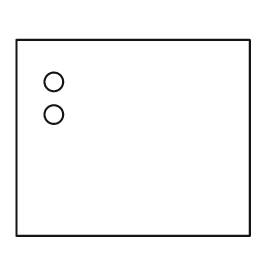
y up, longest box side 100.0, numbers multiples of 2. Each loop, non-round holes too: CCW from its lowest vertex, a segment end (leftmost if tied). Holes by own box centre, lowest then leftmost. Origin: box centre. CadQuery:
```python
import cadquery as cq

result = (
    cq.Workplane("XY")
    .moveTo(-50.0, -42.0)
    .lineTo(50.0, -42.0)
    .lineTo(50.0, 42.0)
    .lineTo(-50.0, 42.0)
    .close()
    .moveTo(-34.0, 10.0)
    .circle(4.0)
    .moveTo(-34.0, 24.0)
    .circle(4.0)
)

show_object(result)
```